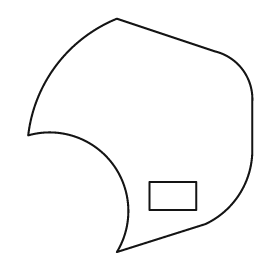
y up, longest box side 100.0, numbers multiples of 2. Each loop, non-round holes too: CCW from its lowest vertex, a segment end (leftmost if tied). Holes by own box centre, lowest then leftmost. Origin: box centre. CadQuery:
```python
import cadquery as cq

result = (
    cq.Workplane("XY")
    .moveTo(-10.0, -50.0)
    .lineTo(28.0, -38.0)
    .threePointArc((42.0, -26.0), (48.0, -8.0))
    .lineTo(48.0, 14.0)
    .threePointArc((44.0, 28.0), (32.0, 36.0))
    .lineTo(-10.0, 50.0)
    .threePointArc((-36.0, 30.0), (-48.0, 0.0))
    .threePointArc((-12.0, -12.0), (-10.0, -50.0))
    .close()
    .moveTo(4.0, -32.0)
    .lineTo(24.0, -32.0)
    .lineTo(24.0, -20.0)
    .lineTo(4.0, -20.0)
    .close()
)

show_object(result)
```